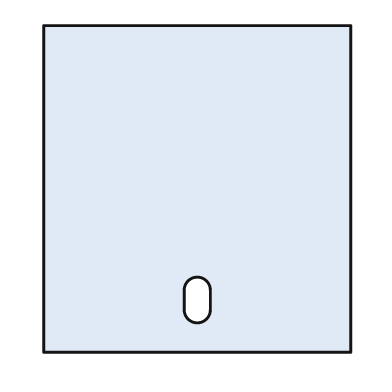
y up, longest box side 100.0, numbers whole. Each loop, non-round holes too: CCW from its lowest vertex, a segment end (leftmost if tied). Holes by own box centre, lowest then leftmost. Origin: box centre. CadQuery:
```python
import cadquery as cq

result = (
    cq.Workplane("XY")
    .moveTo(-47.0, -50.0)
    .lineTo(47.0, -50.0)
    .lineTo(47.0, 50.0)
    .lineTo(-47.0, 50.0)
    .close()
    .moveTo(-4.0, -37.0)
    .threePointArc((0.0, -41.0), (4.0, -37.0))
    .lineTo(4.0, -31.0)
    .threePointArc((0.0, -27.0), (-4.0, -31.0))
    .close()
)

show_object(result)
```